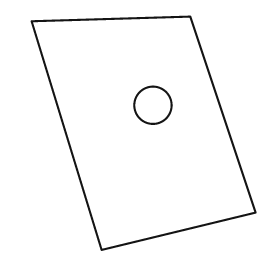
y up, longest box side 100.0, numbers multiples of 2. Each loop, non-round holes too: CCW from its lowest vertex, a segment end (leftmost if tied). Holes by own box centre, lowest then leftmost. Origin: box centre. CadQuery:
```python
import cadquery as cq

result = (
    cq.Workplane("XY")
    .moveTo(-18.0, -50.0)
    .lineTo(48.0, -34.0)
    .lineTo(20.0, 50.0)
    .lineTo(-48.0, 48.0)
    .close()
    .moveTo(4.0, 12.0)
    .circle(8.0)
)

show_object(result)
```